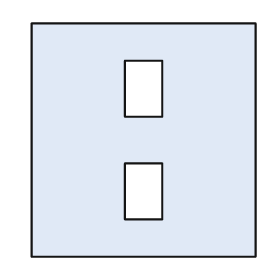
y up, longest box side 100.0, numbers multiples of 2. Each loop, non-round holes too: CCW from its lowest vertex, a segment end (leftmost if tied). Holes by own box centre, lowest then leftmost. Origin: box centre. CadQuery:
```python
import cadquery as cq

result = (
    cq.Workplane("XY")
    .moveTo(-48.0, -50.0)
    .lineTo(48.0, -50.0)
    .lineTo(48.0, 50.0)
    .lineTo(-48.0, 50.0)
    .close()
    .moveTo(-8.0, -34.0)
    .lineTo(8.0, -34.0)
    .lineTo(8.0, -10.0)
    .lineTo(-8.0, -10.0)
    .close()
    .moveTo(-8.0, 10.0)
    .lineTo(8.0, 10.0)
    .lineTo(8.0, 34.0)
    .lineTo(-8.0, 34.0)
    .close()
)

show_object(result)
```